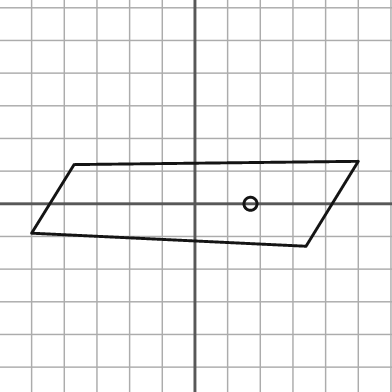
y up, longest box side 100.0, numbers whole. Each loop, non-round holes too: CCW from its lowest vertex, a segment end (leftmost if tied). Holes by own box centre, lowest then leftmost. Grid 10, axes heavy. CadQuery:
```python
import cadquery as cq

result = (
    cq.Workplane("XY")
    .moveTo(34.0, -13.0)
    .lineTo(50.0, 13.0)
    .lineTo(-37.0, 12.0)
    .lineTo(-50.0, -9.0)
    .close()
    .moveTo(17.0, 0.0)
    .circle(2.0)
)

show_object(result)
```